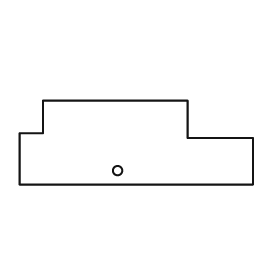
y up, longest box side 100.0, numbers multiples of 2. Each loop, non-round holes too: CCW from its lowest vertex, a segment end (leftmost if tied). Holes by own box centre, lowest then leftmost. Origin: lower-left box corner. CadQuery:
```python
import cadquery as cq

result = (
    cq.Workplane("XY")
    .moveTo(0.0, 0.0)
    .lineTo(100.0, 0.0)
    .lineTo(100.0, 20.0)
    .lineTo(72.0, 20.0)
    .lineTo(72.0, 36.0)
    .lineTo(10.0, 36.0)
    .lineTo(10.0, 22.0)
    .lineTo(0.0, 22.0)
    .close()
    .moveTo(42.0, 6.0)
    .circle(2.0)
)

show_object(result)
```